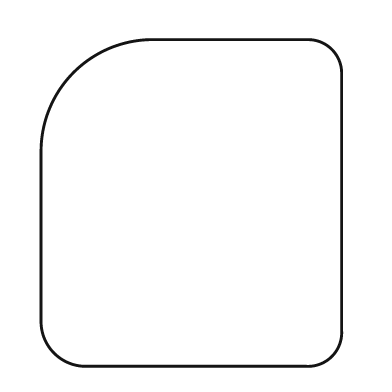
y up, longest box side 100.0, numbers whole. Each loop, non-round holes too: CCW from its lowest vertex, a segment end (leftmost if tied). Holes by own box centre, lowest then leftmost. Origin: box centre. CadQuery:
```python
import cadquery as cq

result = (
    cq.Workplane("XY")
    .moveTo(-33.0, -50.0)
    .lineTo(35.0, -50.0)
    .threePointArc((43.0, -47.0), (46.0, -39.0))
    .lineTo(46.0, 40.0)
    .threePointArc((43.0, 47.0), (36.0, 50.0))
    .lineTo(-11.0, 50.0)
    .threePointArc((-36.0, 40.0), (-46.0, 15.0))
    .lineTo(-46.0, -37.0)
    .threePointArc((-42.0, -46.0), (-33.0, -50.0))
    .close()
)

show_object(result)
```